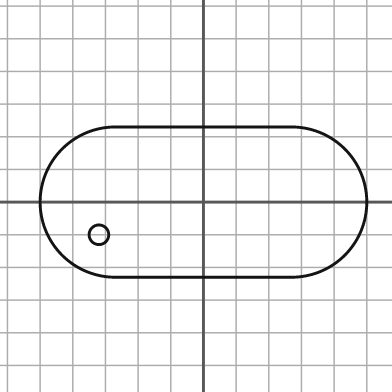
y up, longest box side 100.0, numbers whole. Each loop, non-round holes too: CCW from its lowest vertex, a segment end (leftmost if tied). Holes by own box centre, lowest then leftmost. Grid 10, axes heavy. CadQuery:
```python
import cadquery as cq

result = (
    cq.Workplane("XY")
    .moveTo(-27.0, -23.0)
    .lineTo(27.0, -23.0)
    .threePointArc((50.0, 0.0), (27.0, 23.0))
    .lineTo(-27.0, 23.0)
    .threePointArc((-50.0, 0.0), (-27.0, -23.0))
    .close()
    .moveTo(-32.0, -10.0)
    .circle(3.0)
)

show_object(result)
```